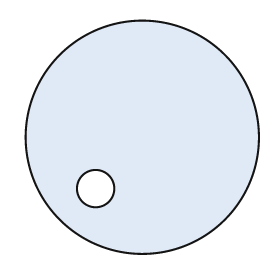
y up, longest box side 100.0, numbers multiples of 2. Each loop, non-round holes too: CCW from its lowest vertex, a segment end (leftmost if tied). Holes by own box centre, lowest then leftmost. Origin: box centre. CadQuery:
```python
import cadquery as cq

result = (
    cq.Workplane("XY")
    .moveTo(0.0, 0.0)
    .circle(50.0)
    .moveTo(-20.0, -22.0)
    .circle(8.0)
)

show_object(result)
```